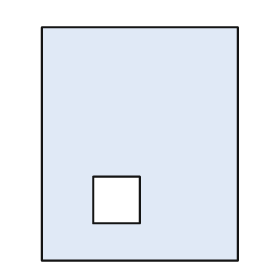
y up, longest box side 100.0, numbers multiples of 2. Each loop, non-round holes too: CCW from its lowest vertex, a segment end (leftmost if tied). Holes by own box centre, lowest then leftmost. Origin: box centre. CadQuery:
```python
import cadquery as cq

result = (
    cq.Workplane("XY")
    .moveTo(-42.0, -50.0)
    .lineTo(42.0, -50.0)
    .lineTo(42.0, 50.0)
    .lineTo(-42.0, 50.0)
    .close()
    .moveTo(-20.0, -34.0)
    .lineTo(0.0, -34.0)
    .lineTo(0.0, -14.0)
    .lineTo(-20.0, -14.0)
    .close()
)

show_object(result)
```